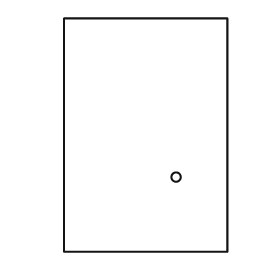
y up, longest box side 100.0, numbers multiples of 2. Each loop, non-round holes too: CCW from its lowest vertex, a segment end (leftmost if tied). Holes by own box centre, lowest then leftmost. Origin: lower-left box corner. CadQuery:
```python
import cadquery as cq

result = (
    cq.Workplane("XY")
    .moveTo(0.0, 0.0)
    .lineTo(70.0, 0.0)
    .lineTo(70.0, 100.0)
    .lineTo(0.0, 100.0)
    .close()
    .moveTo(48.0, 32.0)
    .circle(2.0)
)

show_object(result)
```